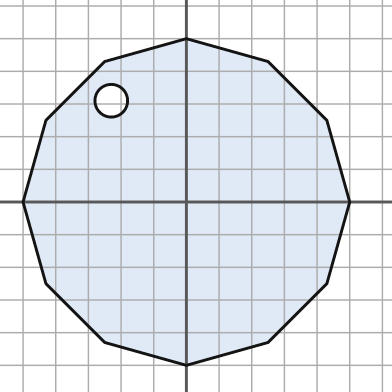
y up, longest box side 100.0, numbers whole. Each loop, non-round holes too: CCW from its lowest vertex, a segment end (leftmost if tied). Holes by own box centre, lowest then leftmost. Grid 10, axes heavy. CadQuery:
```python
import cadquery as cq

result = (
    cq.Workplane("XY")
    .moveTo(0.0, -50.0)
    .lineTo(25.0, -43.0)
    .lineTo(43.0, -25.0)
    .lineTo(50.0, 0.0)
    .lineTo(43.0, 25.0)
    .lineTo(25.0, 43.0)
    .lineTo(0.0, 50.0)
    .lineTo(-25.0, 43.0)
    .lineTo(-43.0, 25.0)
    .lineTo(-50.0, 0.0)
    .lineTo(-43.0, -25.0)
    .lineTo(-25.0, -43.0)
    .close()
    .moveTo(-23.0, 31.0)
    .circle(5.0)
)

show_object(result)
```